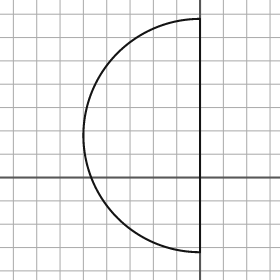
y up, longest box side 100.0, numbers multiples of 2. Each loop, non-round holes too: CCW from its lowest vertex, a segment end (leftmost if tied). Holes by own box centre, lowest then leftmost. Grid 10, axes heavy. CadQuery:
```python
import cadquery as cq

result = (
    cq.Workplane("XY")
    .moveTo(0.0, -32.0)
    .lineTo(0.0, 68.0)
    .threePointArc((-50.0, 18.0), (0.0, -32.0))
    .close()
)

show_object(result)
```